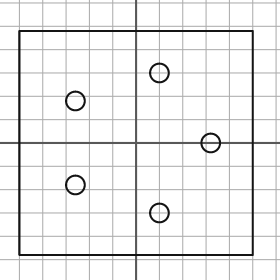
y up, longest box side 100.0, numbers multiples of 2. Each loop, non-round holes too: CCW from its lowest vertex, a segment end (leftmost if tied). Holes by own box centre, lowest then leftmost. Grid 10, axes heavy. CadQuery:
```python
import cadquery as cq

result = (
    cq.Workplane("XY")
    .moveTo(-50.0, -48.0)
    .lineTo(50.0, -48.0)
    .lineTo(50.0, 48.0)
    .lineTo(-50.0, 48.0)
    .close()
    .moveTo(10.0, -30.0)
    .circle(4.0)
    .moveTo(-26.0, -18.0)
    .circle(4.0)
    .moveTo(32.0, 0.0)
    .circle(4.0)
    .moveTo(-26.0, 18.0)
    .circle(4.0)
    .moveTo(10.0, 30.0)
    .circle(4.0)
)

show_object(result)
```